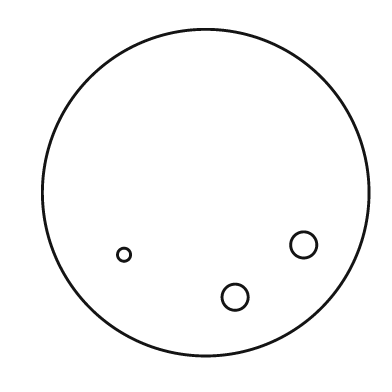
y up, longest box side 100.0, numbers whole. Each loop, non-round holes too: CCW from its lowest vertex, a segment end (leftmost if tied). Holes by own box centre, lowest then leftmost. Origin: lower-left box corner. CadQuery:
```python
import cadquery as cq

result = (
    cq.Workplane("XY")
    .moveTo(50.0, 50.0)
    .circle(50.0)
    .moveTo(59.0, 18.0)
    .circle(4.0)
    .moveTo(25.0, 31.0)
    .circle(2.0)
    .moveTo(80.0, 34.0)
    .circle(4.0)
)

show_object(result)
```